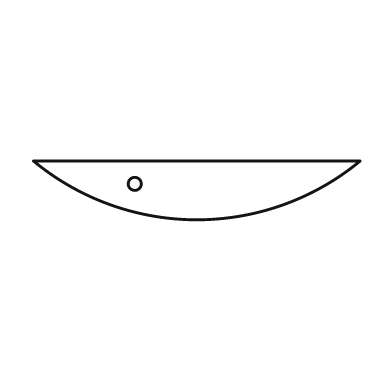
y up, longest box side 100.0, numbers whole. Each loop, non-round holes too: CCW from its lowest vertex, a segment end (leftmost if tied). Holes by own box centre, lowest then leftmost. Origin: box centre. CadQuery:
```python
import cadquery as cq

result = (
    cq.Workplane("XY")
    .moveTo(-50.0, 9.0)
    .threePointArc((0.0, -9.0), (50.0, 9.0))
    .close()
    .moveTo(-19.0, 2.0)
    .circle(2.0)
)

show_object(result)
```